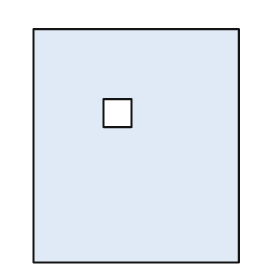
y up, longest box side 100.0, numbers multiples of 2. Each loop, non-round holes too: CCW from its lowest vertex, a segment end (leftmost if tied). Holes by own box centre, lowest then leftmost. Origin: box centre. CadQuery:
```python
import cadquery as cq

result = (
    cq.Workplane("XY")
    .moveTo(-44.0, -50.0)
    .lineTo(44.0, -50.0)
    .lineTo(44.0, 50.0)
    .lineTo(-44.0, 50.0)
    .close()
    .moveTo(-14.0, 8.0)
    .lineTo(-2.0, 8.0)
    .lineTo(-2.0, 20.0)
    .lineTo(-14.0, 20.0)
    .close()
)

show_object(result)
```